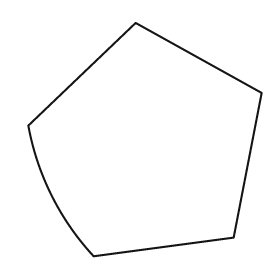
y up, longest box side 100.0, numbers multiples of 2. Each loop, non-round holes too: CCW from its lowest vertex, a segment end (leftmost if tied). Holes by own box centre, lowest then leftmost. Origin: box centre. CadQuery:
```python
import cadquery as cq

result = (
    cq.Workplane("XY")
    .moveTo(-22.0, -50.0)
    .lineTo(38.0, -42.0)
    .lineTo(50.0, 20.0)
    .lineTo(-4.0, 50.0)
    .lineTo(-50.0, 6.0)
    .threePointArc((-40.0, -24.0), (-22.0, -50.0))
    .close()
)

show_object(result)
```